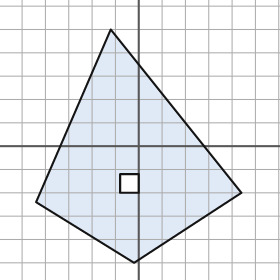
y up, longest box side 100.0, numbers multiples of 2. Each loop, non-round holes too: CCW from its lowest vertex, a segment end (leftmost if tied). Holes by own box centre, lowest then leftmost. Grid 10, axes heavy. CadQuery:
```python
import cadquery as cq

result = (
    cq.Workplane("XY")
    .moveTo(-2.0, -50.0)
    .lineTo(44.0, -20.0)
    .lineTo(-12.0, 50.0)
    .lineTo(-44.0, -24.0)
    .close()
    .moveTo(-8.0, -20.0)
    .lineTo(0.0, -20.0)
    .lineTo(0.0, -12.0)
    .lineTo(-8.0, -12.0)
    .close()
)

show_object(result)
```